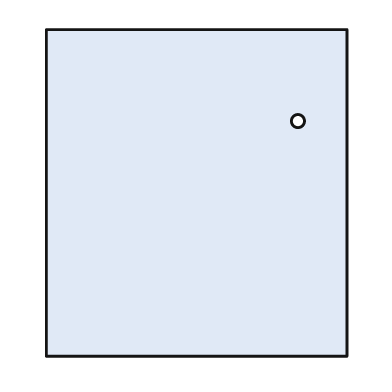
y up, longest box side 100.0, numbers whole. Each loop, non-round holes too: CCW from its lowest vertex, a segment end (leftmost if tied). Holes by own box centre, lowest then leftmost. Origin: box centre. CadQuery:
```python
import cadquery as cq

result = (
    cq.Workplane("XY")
    .moveTo(-46.0, -50.0)
    .lineTo(46.0, -50.0)
    .lineTo(46.0, 50.0)
    .lineTo(-46.0, 50.0)
    .close()
    .moveTo(31.0, 22.0)
    .circle(2.0)
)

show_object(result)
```